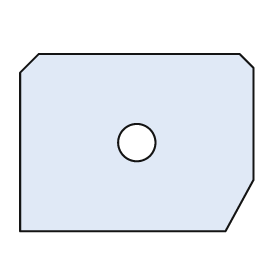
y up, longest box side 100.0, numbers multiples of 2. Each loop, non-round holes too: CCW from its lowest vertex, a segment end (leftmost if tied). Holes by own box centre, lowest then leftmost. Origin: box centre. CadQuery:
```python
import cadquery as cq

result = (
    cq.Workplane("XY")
    .moveTo(-50.0, -38.0)
    .lineTo(38.0, -38.0)
    .lineTo(50.0, -16.0)
    .lineTo(50.0, 32.0)
    .lineTo(44.0, 38.0)
    .lineTo(-42.0, 38.0)
    .lineTo(-50.0, 30.0)
    .close()
    .moveTo(0.0, 0.0)
    .circle(8.0)
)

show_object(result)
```